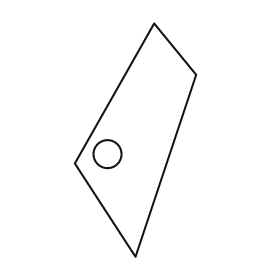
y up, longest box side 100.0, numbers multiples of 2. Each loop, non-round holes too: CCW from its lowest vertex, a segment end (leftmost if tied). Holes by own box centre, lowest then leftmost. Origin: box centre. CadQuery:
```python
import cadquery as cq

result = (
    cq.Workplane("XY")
    .moveTo(0.0, -50.0)
    .lineTo(26.0, 28.0)
    .lineTo(8.0, 50.0)
    .lineTo(-26.0, -10.0)
    .close()
    .moveTo(-12.0, -6.0)
    .circle(6.0)
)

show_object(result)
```